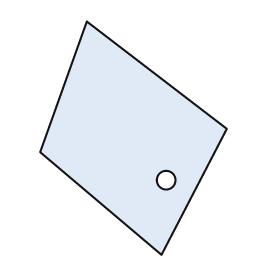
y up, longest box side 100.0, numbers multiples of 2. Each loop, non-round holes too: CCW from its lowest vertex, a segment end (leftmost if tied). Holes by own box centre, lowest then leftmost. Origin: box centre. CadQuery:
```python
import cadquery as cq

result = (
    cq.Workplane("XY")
    .moveTo(12.0, -50.0)
    .lineTo(40.0, 4.0)
    .lineTo(-20.0, 50.0)
    .lineTo(-40.0, -6.0)
    .close()
    .moveTo(14.0, -18.0)
    .circle(4.0)
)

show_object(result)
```